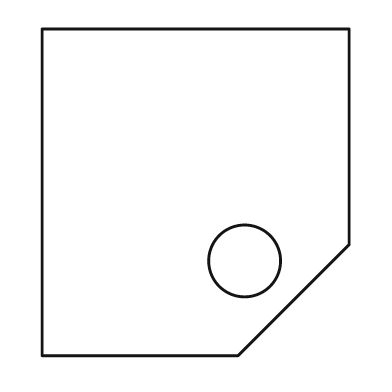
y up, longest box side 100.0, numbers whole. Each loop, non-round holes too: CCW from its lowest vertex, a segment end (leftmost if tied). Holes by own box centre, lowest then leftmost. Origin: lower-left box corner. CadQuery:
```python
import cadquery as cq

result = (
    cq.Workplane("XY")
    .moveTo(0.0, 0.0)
    .lineTo(60.0, 0.0)
    .lineTo(94.0, 34.0)
    .lineTo(94.0, 100.0)
    .lineTo(0.0, 100.0)
    .close()
    .moveTo(62.0, 29.0)
    .circle(11.0)
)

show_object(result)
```